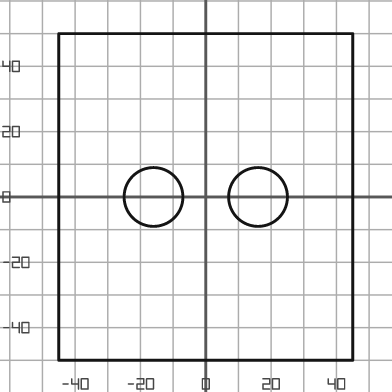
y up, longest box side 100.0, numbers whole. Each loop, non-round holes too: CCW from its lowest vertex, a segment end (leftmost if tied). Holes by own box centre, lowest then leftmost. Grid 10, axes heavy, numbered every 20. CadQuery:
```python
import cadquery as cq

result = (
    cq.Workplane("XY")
    .moveTo(-45.0, -50.0)
    .lineTo(45.0, -50.0)
    .lineTo(45.0, 50.0)
    .lineTo(-45.0, 50.0)
    .close()
    .moveTo(-16.0, 0.0)
    .circle(9.0)
    .moveTo(16.0, 0.0)
    .circle(9.0)
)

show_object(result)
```